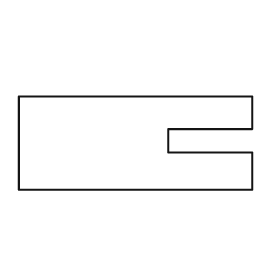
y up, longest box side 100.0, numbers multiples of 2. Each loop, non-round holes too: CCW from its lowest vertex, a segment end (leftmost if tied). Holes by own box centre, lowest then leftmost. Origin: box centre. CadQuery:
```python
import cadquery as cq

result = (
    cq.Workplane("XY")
    .moveTo(-50.0, -20.0)
    .lineTo(50.0, -20.0)
    .lineTo(50.0, -4.0)
    .lineTo(14.0, -4.0)
    .lineTo(14.0, 6.0)
    .lineTo(50.0, 6.0)
    .lineTo(50.0, 20.0)
    .lineTo(-50.0, 20.0)
    .close()
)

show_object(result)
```